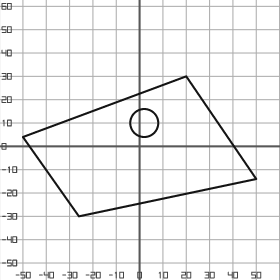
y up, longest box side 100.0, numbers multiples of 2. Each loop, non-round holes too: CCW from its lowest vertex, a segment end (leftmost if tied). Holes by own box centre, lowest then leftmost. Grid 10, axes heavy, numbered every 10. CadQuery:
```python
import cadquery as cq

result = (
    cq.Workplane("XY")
    .moveTo(-26.0, -30.0)
    .lineTo(50.0, -14.0)
    .lineTo(20.0, 30.0)
    .lineTo(-50.0, 4.0)
    .close()
    .moveTo(2.0, 10.0)
    .circle(6.0)
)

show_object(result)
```